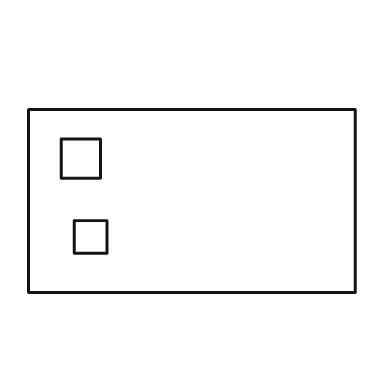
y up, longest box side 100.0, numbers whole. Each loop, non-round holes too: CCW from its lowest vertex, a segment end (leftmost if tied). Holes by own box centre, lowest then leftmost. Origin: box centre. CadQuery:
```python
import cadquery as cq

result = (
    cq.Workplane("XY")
    .moveTo(-50.0, -28.0)
    .lineTo(50.0, -28.0)
    .lineTo(50.0, 28.0)
    .lineTo(-50.0, 28.0)
    .close()
    .moveTo(-36.0, -16.0)
    .lineTo(-26.0, -16.0)
    .lineTo(-26.0, -6.0)
    .lineTo(-36.0, -6.0)
    .close()
    .moveTo(-40.0, 7.0)
    .lineTo(-28.0, 7.0)
    .lineTo(-28.0, 19.0)
    .lineTo(-40.0, 19.0)
    .close()
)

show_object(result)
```